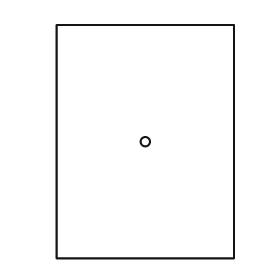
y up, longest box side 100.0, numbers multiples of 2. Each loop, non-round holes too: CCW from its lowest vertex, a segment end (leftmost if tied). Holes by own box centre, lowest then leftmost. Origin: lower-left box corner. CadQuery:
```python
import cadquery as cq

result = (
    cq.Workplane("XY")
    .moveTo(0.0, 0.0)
    .lineTo(76.0, 0.0)
    .lineTo(76.0, 100.0)
    .lineTo(0.0, 100.0)
    .close()
    .moveTo(38.0, 50.0)
    .circle(2.0)
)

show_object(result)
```